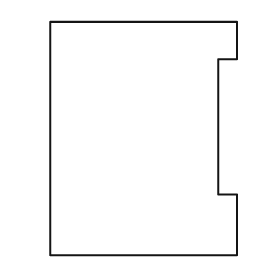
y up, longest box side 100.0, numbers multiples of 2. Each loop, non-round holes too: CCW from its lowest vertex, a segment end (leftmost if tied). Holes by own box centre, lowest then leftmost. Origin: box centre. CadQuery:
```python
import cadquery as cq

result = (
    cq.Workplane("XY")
    .moveTo(-40.0, -50.0)
    .lineTo(40.0, -50.0)
    .lineTo(40.0, -24.0)
    .lineTo(32.0, -24.0)
    .lineTo(32.0, 34.0)
    .lineTo(40.0, 34.0)
    .lineTo(40.0, 50.0)
    .lineTo(-40.0, 50.0)
    .close()
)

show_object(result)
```